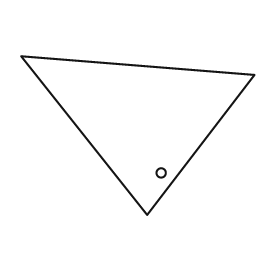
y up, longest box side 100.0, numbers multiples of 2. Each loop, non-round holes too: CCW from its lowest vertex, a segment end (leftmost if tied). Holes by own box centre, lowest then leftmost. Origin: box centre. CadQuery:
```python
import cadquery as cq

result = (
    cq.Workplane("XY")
    .moveTo(4.0, -34.0)
    .lineTo(50.0, 26.0)
    .lineTo(-50.0, 34.0)
    .close()
    .moveTo(10.0, -16.0)
    .circle(2.0)
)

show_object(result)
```